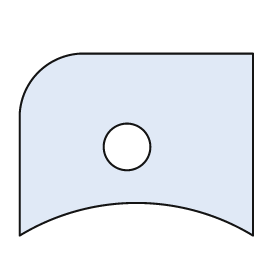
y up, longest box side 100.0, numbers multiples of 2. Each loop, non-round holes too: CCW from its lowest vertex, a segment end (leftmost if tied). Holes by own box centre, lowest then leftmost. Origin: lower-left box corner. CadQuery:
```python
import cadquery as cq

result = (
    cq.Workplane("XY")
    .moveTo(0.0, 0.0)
    .threePointArc((50.0, 14.0), (100.0, 0.0))
    .lineTo(100.0, 78.0)
    .lineTo(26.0, 78.0)
    .threePointArc((8.0, 70.0), (0.0, 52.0))
    .close()
    .moveTo(46.0, 38.0)
    .circle(10.0)
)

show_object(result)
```